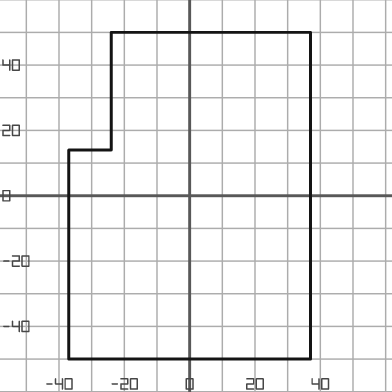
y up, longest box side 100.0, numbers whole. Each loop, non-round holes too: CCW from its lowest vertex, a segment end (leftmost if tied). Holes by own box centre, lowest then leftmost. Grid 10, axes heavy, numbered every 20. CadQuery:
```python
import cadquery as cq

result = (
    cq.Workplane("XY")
    .moveTo(-37.0, -50.0)
    .lineTo(37.0, -50.0)
    .lineTo(37.0, 50.0)
    .lineTo(-24.0, 50.0)
    .lineTo(-24.0, 14.0)
    .lineTo(-37.0, 14.0)
    .close()
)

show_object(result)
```